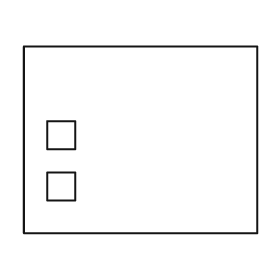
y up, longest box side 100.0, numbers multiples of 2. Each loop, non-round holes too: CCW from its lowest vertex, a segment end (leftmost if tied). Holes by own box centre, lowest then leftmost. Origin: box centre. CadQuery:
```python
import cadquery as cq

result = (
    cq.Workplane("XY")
    .moveTo(-50.0, -40.0)
    .lineTo(50.0, -40.0)
    .lineTo(50.0, 40.0)
    .lineTo(-50.0, 40.0)
    .close()
    .moveTo(-40.0, -26.0)
    .lineTo(-28.0, -26.0)
    .lineTo(-28.0, -14.0)
    .lineTo(-40.0, -14.0)
    .close()
    .moveTo(-40.0, -4.0)
    .lineTo(-28.0, -4.0)
    .lineTo(-28.0, 8.0)
    .lineTo(-40.0, 8.0)
    .close()
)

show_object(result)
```